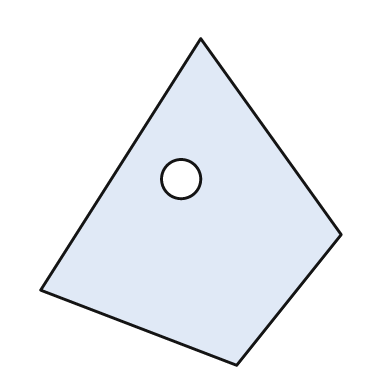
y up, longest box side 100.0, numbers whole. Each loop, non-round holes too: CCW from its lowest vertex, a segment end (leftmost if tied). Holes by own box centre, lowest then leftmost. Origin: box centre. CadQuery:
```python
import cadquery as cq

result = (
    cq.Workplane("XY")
    .moveTo(14.0, -50.0)
    .lineTo(46.0, -10.0)
    .lineTo(3.0, 50.0)
    .lineTo(-46.0, -27.0)
    .close()
    .moveTo(-3.0, 7.0)
    .circle(6.0)
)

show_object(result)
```